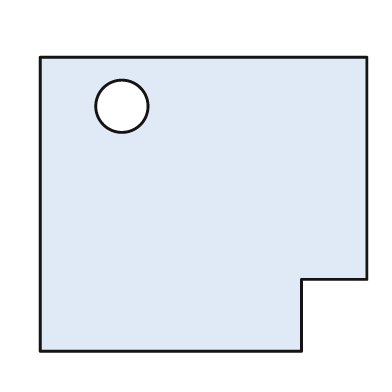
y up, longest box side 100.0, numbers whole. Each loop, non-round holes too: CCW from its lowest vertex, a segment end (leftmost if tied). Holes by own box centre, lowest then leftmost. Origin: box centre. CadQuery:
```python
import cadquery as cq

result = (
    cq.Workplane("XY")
    .moveTo(-50.0, -45.0)
    .lineTo(30.0, -45.0)
    .lineTo(30.0, -23.0)
    .lineTo(50.0, -23.0)
    .lineTo(50.0, 45.0)
    .lineTo(-50.0, 45.0)
    .close()
    .moveTo(-25.0, 30.0)
    .circle(8.0)
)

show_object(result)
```